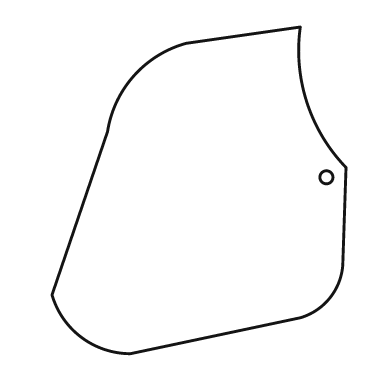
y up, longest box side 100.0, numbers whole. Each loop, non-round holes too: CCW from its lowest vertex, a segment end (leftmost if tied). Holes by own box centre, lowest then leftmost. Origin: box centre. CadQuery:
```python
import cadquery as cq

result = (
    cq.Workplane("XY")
    .moveTo(-21.0, -50.0)
    .lineTo(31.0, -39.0)
    .threePointArc((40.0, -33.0), (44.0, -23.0))
    .lineTo(45.0, 7.0)
    .threePointArc((33.0, 27.0), (31.0, 50.0))
    .lineTo(-4.0, 45.0)
    .threePointArc((-20.0, 35.0), (-28.0, 18.0))
    .lineTo(-45.0, -32.0)
    .threePointArc((-36.0, -45.0), (-21.0, -50.0))
    .close()
    .moveTo(39.0, 4.0)
    .circle(2.0)
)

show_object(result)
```